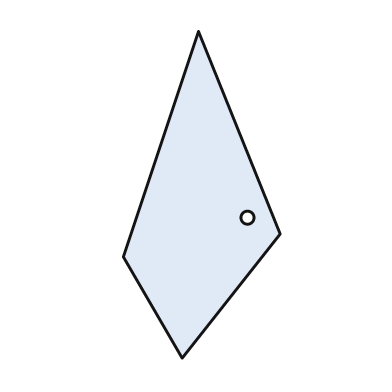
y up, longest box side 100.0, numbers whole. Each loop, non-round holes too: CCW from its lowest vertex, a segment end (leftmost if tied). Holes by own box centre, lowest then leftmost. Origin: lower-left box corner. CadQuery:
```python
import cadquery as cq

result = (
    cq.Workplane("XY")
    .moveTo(18.0, 0.0)
    .lineTo(48.0, 38.0)
    .lineTo(23.0, 100.0)
    .lineTo(0.0, 31.0)
    .close()
    .moveTo(38.0, 43.0)
    .circle(2.0)
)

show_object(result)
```